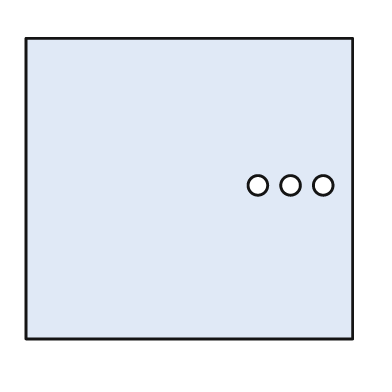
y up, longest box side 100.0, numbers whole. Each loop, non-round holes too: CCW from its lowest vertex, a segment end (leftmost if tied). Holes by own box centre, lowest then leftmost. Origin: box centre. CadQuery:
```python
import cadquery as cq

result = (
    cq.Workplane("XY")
    .moveTo(-50.0, -46.0)
    .lineTo(50.0, -46.0)
    .lineTo(50.0, 46.0)
    .lineTo(-50.0, 46.0)
    .close()
    .moveTo(21.0, 1.0)
    .circle(3.0)
    .moveTo(31.0, 1.0)
    .circle(3.0)
    .moveTo(41.0, 1.0)
    .circle(3.0)
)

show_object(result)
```